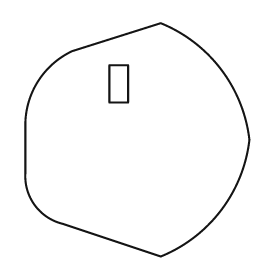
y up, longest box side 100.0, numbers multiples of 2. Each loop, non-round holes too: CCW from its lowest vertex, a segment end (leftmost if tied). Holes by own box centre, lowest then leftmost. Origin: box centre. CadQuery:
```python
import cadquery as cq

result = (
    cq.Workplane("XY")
    .moveTo(10.0, -50.0)
    .threePointArc((36.0, -30.0), (48.0, 0.0))
    .threePointArc((36.0, 30.0), (10.0, 50.0))
    .lineTo(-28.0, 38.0)
    .threePointArc((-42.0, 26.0), (-48.0, 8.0))
    .lineTo(-48.0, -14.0)
    .threePointArc((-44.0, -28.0), (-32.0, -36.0))
    .close()
    .moveTo(-12.0, 16.0)
    .lineTo(-4.0, 16.0)
    .lineTo(-4.0, 32.0)
    .lineTo(-12.0, 32.0)
    .close()
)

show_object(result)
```